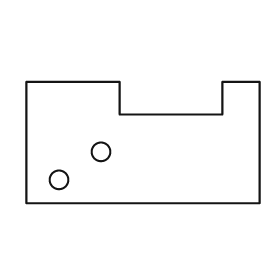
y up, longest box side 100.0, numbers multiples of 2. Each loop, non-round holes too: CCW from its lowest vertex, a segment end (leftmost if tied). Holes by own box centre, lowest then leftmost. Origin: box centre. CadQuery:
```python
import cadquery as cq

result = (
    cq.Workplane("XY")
    .moveTo(-50.0, -26.0)
    .lineTo(50.0, -26.0)
    .lineTo(50.0, 26.0)
    .lineTo(34.0, 26.0)
    .lineTo(34.0, 12.0)
    .lineTo(-10.0, 12.0)
    .lineTo(-10.0, 26.0)
    .lineTo(-50.0, 26.0)
    .close()
    .moveTo(-36.0, -16.0)
    .circle(4.0)
    .moveTo(-18.0, -4.0)
    .circle(4.0)
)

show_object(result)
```